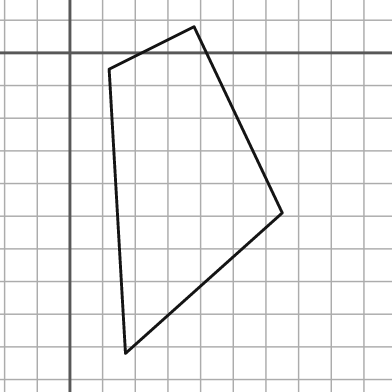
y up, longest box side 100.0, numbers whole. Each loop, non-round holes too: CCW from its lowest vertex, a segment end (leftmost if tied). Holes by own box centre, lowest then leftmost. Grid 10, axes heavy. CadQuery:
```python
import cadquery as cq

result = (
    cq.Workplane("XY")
    .moveTo(17.0, -92.0)
    .lineTo(65.0, -49.0)
    .lineTo(38.0, 8.0)
    .lineTo(12.0, -5.0)
    .close()
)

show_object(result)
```